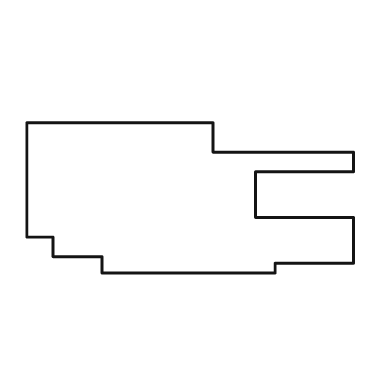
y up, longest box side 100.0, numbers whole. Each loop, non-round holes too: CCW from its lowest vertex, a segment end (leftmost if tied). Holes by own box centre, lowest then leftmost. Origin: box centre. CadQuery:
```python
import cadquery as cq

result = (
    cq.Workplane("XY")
    .moveTo(-27.0, -23.0)
    .lineTo(26.0, -23.0)
    .lineTo(26.0, -20.0)
    .lineTo(50.0, -20.0)
    .lineTo(50.0, -6.0)
    .lineTo(20.0, -6.0)
    .lineTo(20.0, 8.0)
    .lineTo(50.0, 8.0)
    .lineTo(50.0, 14.0)
    .lineTo(7.0, 14.0)
    .lineTo(7.0, 23.0)
    .lineTo(-50.0, 23.0)
    .lineTo(-50.0, -12.0)
    .lineTo(-42.0, -12.0)
    .lineTo(-42.0, -18.0)
    .lineTo(-27.0, -18.0)
    .close()
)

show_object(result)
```